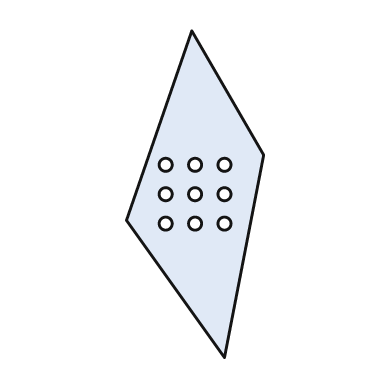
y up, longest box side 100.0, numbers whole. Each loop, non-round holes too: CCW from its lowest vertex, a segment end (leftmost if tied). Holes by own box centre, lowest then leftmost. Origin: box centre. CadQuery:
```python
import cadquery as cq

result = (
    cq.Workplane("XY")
    .moveTo(9.0, -50.0)
    .lineTo(21.0, 12.0)
    .lineTo(-1.0, 50.0)
    .lineTo(-21.0, -8.0)
    .close()
    .moveTo(-9.0, -9.0)
    .circle(2.0)
    .moveTo(0.0, -9.0)
    .circle(2.0)
    .moveTo(9.0, -9.0)
    .circle(2.0)
    .moveTo(-9.0, 0.0)
    .circle(2.0)
    .moveTo(0.0, 0.0)
    .circle(2.0)
    .moveTo(9.0, 0.0)
    .circle(2.0)
    .moveTo(-9.0, 9.0)
    .circle(2.0)
    .moveTo(0.0, 9.0)
    .circle(2.0)
    .moveTo(9.0, 9.0)
    .circle(2.0)
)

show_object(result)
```